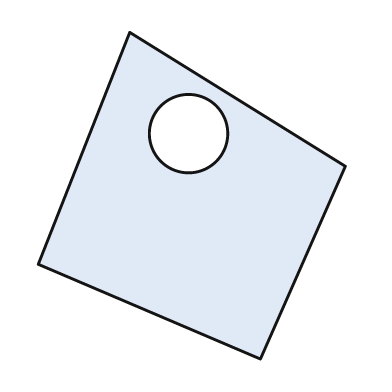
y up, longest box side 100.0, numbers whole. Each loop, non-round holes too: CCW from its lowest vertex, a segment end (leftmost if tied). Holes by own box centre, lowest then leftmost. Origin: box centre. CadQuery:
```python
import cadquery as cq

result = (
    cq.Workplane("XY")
    .moveTo(21.0, -50.0)
    .lineTo(47.0, 9.0)
    .lineTo(-19.0, 50.0)
    .lineTo(-47.0, -21.0)
    .close()
    .moveTo(-1.0, 19.0)
    .circle(12.0)
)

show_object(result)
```